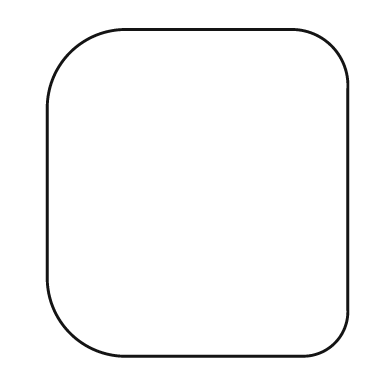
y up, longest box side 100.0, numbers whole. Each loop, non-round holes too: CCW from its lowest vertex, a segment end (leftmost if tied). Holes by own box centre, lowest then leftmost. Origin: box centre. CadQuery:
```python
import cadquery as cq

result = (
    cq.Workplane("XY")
    .moveTo(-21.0, -50.0)
    .lineTo(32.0, -50.0)
    .threePointArc((42.0, -46.0), (46.0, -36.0))
    .lineTo(46.0, 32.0)
    .threePointArc((41.0, 45.0), (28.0, 50.0))
    .lineTo(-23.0, 50.0)
    .threePointArc((-39.0, 43.0), (-46.0, 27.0))
    .lineTo(-46.0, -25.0)
    .threePointArc((-39.0, -43.0), (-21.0, -50.0))
    .close()
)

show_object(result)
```